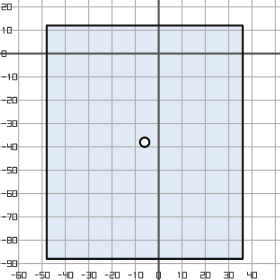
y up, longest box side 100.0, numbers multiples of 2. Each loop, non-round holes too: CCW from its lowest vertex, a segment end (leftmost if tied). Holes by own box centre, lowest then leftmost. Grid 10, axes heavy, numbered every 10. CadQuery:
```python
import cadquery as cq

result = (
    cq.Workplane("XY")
    .moveTo(-48.0, -88.0)
    .lineTo(36.0, -88.0)
    .lineTo(36.0, 12.0)
    .lineTo(-48.0, 12.0)
    .close()
    .moveTo(-6.0, -38.0)
    .circle(2.0)
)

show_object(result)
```